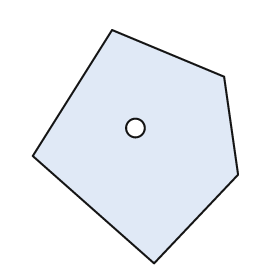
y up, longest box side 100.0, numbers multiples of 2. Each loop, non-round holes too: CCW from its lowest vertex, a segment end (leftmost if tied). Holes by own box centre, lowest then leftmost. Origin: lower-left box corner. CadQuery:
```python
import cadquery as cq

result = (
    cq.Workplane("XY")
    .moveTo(52.0, 0.0)
    .lineTo(88.0, 38.0)
    .lineTo(82.0, 80.0)
    .lineTo(34.0, 100.0)
    .lineTo(0.0, 46.0)
    .close()
    .moveTo(44.0, 58.0)
    .circle(4.0)
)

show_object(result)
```